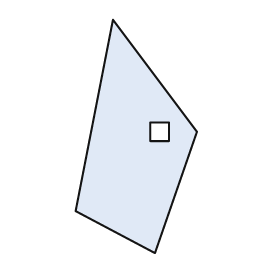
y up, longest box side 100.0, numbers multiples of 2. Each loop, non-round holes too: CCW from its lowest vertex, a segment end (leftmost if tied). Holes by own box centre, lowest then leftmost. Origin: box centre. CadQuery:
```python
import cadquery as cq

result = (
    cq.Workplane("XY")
    .moveTo(8.0, -50.0)
    .lineTo(26.0, 2.0)
    .lineTo(-10.0, 50.0)
    .lineTo(-26.0, -32.0)
    .close()
    .moveTo(6.0, -2.0)
    .lineTo(14.0, -2.0)
    .lineTo(14.0, 6.0)
    .lineTo(6.0, 6.0)
    .close()
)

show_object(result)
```